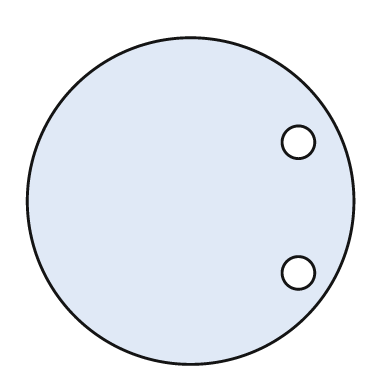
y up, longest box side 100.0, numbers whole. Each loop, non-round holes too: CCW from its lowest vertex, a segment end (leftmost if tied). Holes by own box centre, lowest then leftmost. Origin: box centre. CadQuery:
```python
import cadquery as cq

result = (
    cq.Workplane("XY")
    .moveTo(0.0, 0.0)
    .circle(50.0)
    .moveTo(33.0, -22.0)
    .circle(5.0)
    .moveTo(33.0, 18.0)
    .circle(5.0)
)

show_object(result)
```